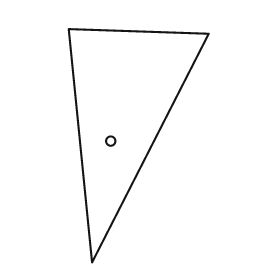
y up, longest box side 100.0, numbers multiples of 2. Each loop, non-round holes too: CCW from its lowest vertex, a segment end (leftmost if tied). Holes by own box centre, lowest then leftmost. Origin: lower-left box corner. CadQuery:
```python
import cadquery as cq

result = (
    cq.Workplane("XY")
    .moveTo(10.0, 0.0)
    .lineTo(60.0, 98.0)
    .lineTo(0.0, 100.0)
    .close()
    .moveTo(18.0, 52.0)
    .circle(2.0)
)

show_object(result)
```